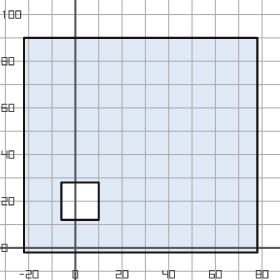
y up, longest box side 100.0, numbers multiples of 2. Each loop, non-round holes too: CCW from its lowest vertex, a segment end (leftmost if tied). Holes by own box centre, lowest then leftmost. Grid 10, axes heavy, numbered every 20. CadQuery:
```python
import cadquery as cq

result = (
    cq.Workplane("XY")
    .moveTo(-22.0, -2.0)
    .lineTo(78.0, -2.0)
    .lineTo(78.0, 90.0)
    .lineTo(-22.0, 90.0)
    .close()
    .moveTo(-6.0, 12.0)
    .lineTo(10.0, 12.0)
    .lineTo(10.0, 28.0)
    .lineTo(-6.0, 28.0)
    .close()
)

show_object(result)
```